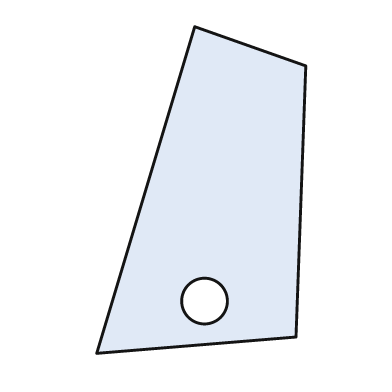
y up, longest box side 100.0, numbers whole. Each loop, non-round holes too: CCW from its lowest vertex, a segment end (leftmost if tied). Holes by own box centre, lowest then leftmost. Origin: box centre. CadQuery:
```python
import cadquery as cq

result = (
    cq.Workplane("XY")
    .moveTo(-32.0, -50.0)
    .lineTo(29.0, -45.0)
    .lineTo(32.0, 38.0)
    .lineTo(-2.0, 50.0)
    .close()
    .moveTo(1.0, -34.0)
    .circle(7.0)
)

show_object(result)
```